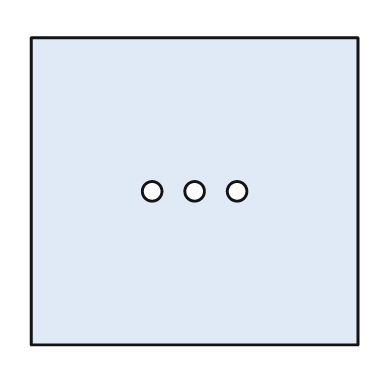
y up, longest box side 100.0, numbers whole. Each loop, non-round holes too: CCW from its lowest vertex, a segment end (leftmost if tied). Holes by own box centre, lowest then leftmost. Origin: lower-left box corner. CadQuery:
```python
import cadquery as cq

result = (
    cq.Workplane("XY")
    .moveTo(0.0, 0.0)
    .lineTo(100.0, 0.0)
    .lineTo(100.0, 94.0)
    .lineTo(0.0, 94.0)
    .close()
    .moveTo(37.0, 47.0)
    .circle(3.0)
    .moveTo(50.0, 47.0)
    .circle(3.0)
    .moveTo(63.0, 47.0)
    .circle(3.0)
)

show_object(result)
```